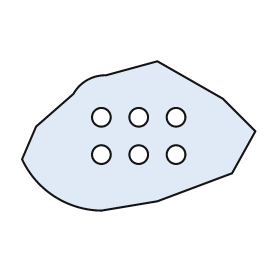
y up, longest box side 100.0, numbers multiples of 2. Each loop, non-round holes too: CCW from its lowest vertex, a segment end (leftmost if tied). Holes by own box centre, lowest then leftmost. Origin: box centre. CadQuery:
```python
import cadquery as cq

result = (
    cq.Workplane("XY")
    .moveTo(-16.0, -32.0)
    .lineTo(8.0, -28.0)
    .lineTo(40.0, -16.0)
    .lineTo(50.0, 2.0)
    .lineTo(36.0, 16.0)
    .lineTo(8.0, 32.0)
    .lineTo(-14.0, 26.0)
    .threePointArc((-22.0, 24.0), (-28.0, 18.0))
    .lineTo(-44.0, 4.0)
    .lineTo(-50.0, -10.0)
    .threePointArc((-36.0, -26.0), (-16.0, -32.0))
    .close()
    .moveTo(-16.0, -8.0)
    .circle(4.0)
    .moveTo(0.0, -8.0)
    .circle(4.0)
    .moveTo(16.0, -8.0)
    .circle(4.0)
    .moveTo(-16.0, 8.0)
    .circle(4.0)
    .moveTo(0.0, 8.0)
    .circle(4.0)
    .moveTo(16.0, 8.0)
    .circle(4.0)
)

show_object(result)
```